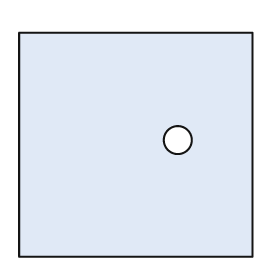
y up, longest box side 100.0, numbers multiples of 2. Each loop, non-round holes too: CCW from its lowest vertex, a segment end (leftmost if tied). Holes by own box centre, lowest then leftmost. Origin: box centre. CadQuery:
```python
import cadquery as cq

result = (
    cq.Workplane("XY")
    .moveTo(-50.0, -48.0)
    .lineTo(50.0, -48.0)
    .lineTo(50.0, 48.0)
    .lineTo(-50.0, 48.0)
    .close()
    .moveTo(18.0, 2.0)
    .circle(6.0)
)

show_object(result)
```